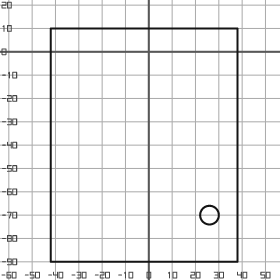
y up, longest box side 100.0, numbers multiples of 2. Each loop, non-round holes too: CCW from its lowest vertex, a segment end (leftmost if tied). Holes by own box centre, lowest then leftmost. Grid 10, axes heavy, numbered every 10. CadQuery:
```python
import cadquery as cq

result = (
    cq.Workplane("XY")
    .moveTo(-42.0, -90.0)
    .lineTo(38.0, -90.0)
    .lineTo(38.0, 10.0)
    .lineTo(-42.0, 10.0)
    .close()
    .moveTo(26.0, -70.0)
    .circle(4.0)
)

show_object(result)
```